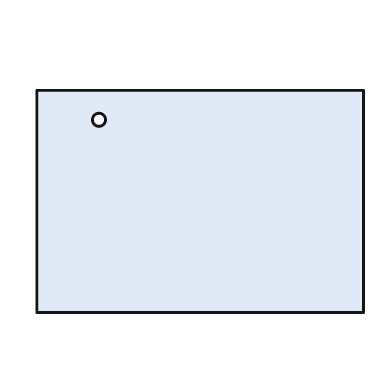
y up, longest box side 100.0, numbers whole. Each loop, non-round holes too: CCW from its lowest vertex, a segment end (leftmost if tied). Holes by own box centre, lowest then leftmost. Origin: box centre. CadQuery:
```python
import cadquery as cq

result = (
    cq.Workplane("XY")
    .moveTo(-50.0, -34.0)
    .lineTo(50.0, -34.0)
    .lineTo(50.0, 34.0)
    .lineTo(-50.0, 34.0)
    .close()
    .moveTo(-31.0, 25.0)
    .circle(2.0)
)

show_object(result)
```